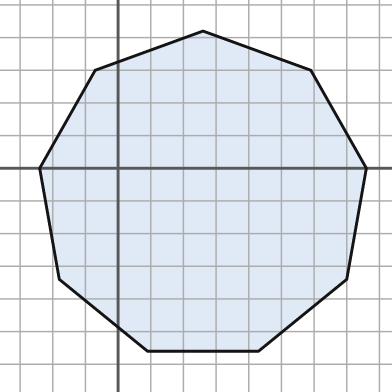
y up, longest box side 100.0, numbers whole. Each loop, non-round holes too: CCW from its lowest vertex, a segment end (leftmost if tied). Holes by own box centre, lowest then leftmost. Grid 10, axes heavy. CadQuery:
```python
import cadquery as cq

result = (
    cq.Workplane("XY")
    .moveTo(9.0, -56.0)
    .lineTo(43.0, -56.0)
    .lineTo(70.0, -34.0)
    .lineTo(76.0, 0.0)
    .lineTo(59.0, 30.0)
    .lineTo(26.0, 42.0)
    .lineTo(-7.0, 30.0)
    .lineTo(-24.0, 0.0)
    .lineTo(-18.0, -34.0)
    .close()
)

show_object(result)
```